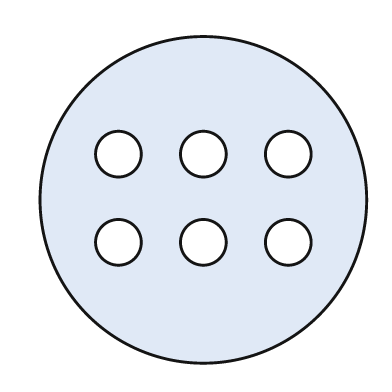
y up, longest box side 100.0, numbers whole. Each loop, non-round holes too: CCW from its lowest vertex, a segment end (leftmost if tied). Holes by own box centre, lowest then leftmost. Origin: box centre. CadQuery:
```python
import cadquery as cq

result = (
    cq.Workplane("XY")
    .moveTo(0.0, 0.0)
    .circle(50.0)
    .moveTo(-26.0, -13.0)
    .circle(7.0)
    .moveTo(0.0, -13.0)
    .circle(7.0)
    .moveTo(26.0, -13.0)
    .circle(7.0)
    .moveTo(-26.0, 14.0)
    .circle(7.0)
    .moveTo(0.0, 14.0)
    .circle(7.0)
    .moveTo(26.0, 14.0)
    .circle(7.0)
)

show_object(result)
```